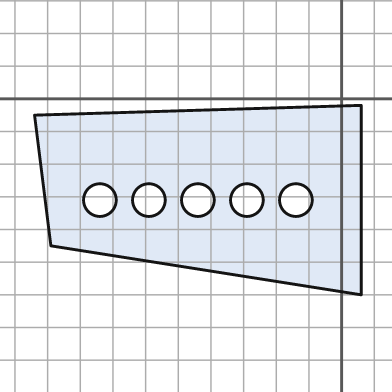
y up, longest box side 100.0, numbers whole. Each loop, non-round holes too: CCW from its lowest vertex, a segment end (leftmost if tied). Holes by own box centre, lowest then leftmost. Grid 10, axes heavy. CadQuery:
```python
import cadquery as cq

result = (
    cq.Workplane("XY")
    .moveTo(6.0, -60.0)
    .lineTo(6.0, -2.0)
    .lineTo(-94.0, -5.0)
    .lineTo(-89.0, -45.0)
    .close()
    .moveTo(-74.0, -31.0)
    .circle(5.0)
    .moveTo(-59.0, -31.0)
    .circle(5.0)
    .moveTo(-44.0, -31.0)
    .circle(5.0)
    .moveTo(-29.0, -31.0)
    .circle(5.0)
    .moveTo(-14.0, -31.0)
    .circle(5.0)
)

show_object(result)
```